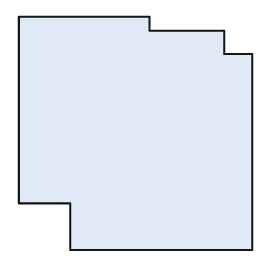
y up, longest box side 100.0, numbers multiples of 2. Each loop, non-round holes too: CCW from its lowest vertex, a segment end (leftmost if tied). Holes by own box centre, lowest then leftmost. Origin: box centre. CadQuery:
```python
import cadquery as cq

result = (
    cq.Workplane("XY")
    .moveTo(-28.0, -50.0)
    .lineTo(50.0, -50.0)
    .lineTo(50.0, 34.0)
    .lineTo(38.0, 34.0)
    .lineTo(38.0, 44.0)
    .lineTo(6.0, 44.0)
    .lineTo(6.0, 50.0)
    .lineTo(-50.0, 50.0)
    .lineTo(-50.0, -30.0)
    .lineTo(-28.0, -30.0)
    .close()
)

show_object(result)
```